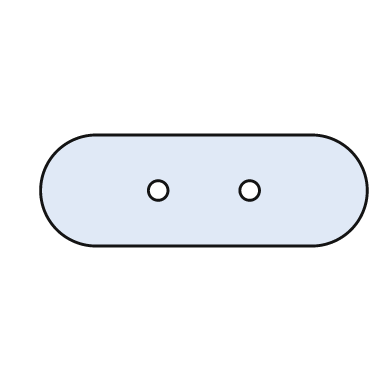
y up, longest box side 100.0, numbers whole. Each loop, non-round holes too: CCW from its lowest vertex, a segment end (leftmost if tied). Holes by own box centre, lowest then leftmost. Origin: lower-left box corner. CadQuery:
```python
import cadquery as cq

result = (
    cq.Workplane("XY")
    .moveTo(17.0, 0.0)
    .lineTo(83.0, 0.0)
    .threePointArc((100.0, 17.0), (83.0, 34.0))
    .lineTo(17.0, 34.0)
    .threePointArc((0.0, 17.0), (17.0, 0.0))
    .close()
    .moveTo(36.0, 17.0)
    .circle(3.0)
    .moveTo(64.0, 17.0)
    .circle(3.0)
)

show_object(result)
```